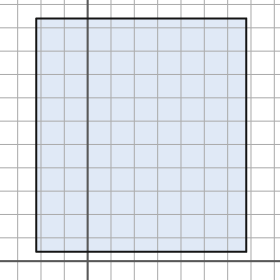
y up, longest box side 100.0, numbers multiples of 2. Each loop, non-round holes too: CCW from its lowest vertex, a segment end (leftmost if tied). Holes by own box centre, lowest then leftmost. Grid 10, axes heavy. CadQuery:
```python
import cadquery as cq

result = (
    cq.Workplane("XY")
    .moveTo(-22.0, 4.0)
    .lineTo(68.0, 4.0)
    .lineTo(68.0, 104.0)
    .lineTo(-22.0, 104.0)
    .close()
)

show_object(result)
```